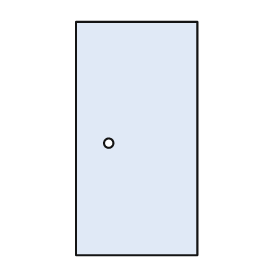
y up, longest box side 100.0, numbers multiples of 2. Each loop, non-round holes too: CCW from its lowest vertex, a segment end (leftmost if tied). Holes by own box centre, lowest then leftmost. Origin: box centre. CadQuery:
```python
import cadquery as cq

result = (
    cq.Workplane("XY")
    .moveTo(-26.0, -50.0)
    .lineTo(26.0, -50.0)
    .lineTo(26.0, 50.0)
    .lineTo(-26.0, 50.0)
    .close()
    .moveTo(-12.0, -2.0)
    .circle(2.0)
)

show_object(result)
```